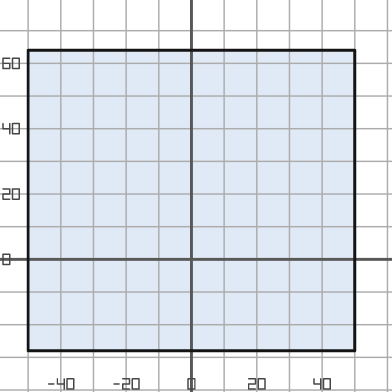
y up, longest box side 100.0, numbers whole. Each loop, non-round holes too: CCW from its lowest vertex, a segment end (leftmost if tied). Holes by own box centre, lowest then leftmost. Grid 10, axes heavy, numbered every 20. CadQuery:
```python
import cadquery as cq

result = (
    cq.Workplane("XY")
    .moveTo(-50.0, -28.0)
    .lineTo(50.0, -28.0)
    .lineTo(50.0, 64.0)
    .lineTo(-50.0, 64.0)
    .close()
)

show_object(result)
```